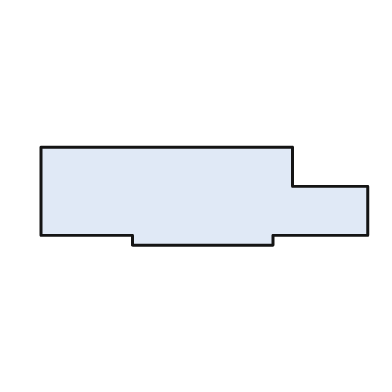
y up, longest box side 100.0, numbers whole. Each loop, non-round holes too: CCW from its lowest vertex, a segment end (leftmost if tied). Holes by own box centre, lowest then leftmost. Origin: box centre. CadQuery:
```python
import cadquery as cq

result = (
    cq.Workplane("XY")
    .moveTo(-22.0, -15.0)
    .lineTo(21.0, -15.0)
    .lineTo(21.0, -12.0)
    .lineTo(50.0, -12.0)
    .lineTo(50.0, 3.0)
    .lineTo(27.0, 3.0)
    .lineTo(27.0, 15.0)
    .lineTo(-50.0, 15.0)
    .lineTo(-50.0, -12.0)
    .lineTo(-22.0, -12.0)
    .close()
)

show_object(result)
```